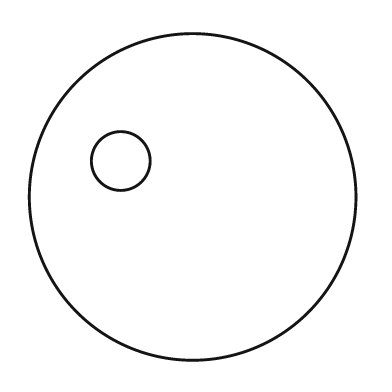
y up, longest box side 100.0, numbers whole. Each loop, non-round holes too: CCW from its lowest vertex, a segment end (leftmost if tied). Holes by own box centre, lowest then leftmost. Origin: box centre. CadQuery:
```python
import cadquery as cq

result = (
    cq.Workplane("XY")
    .moveTo(0.0, 0.0)
    .circle(50.0)
    .moveTo(-22.0, 11.0)
    .circle(9.0)
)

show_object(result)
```